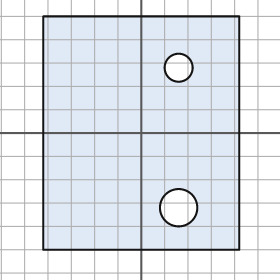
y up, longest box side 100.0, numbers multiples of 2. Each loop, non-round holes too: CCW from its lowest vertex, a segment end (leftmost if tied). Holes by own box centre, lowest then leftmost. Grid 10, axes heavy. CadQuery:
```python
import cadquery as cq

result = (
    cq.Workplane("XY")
    .moveTo(-42.0, -50.0)
    .lineTo(42.0, -50.0)
    .lineTo(42.0, 50.0)
    .lineTo(-42.0, 50.0)
    .close()
    .moveTo(16.0, -32.0)
    .circle(8.0)
    .moveTo(16.0, 28.0)
    .circle(6.0)
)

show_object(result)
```